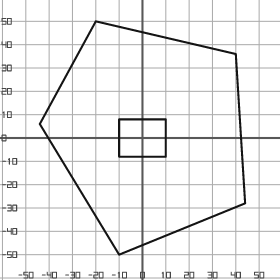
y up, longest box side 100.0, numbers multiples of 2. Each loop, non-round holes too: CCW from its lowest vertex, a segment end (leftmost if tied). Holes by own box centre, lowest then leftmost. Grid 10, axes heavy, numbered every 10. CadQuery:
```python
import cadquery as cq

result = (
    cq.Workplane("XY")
    .moveTo(-10.0, -50.0)
    .lineTo(44.0, -28.0)
    .lineTo(40.0, 36.0)
    .lineTo(-20.0, 50.0)
    .lineTo(-44.0, 6.0)
    .close()
    .moveTo(-10.0, -8.0)
    .lineTo(10.0, -8.0)
    .lineTo(10.0, 8.0)
    .lineTo(-10.0, 8.0)
    .close()
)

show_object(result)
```